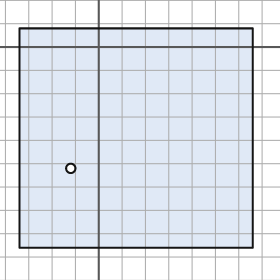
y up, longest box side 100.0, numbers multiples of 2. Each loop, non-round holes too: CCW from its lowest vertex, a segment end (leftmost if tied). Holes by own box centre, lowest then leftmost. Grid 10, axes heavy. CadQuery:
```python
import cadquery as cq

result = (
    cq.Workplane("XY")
    .moveTo(-34.0, -86.0)
    .lineTo(66.0, -86.0)
    .lineTo(66.0, 8.0)
    .lineTo(-34.0, 8.0)
    .close()
    .moveTo(-12.0, -52.0)
    .circle(2.0)
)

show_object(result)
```